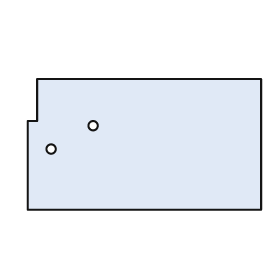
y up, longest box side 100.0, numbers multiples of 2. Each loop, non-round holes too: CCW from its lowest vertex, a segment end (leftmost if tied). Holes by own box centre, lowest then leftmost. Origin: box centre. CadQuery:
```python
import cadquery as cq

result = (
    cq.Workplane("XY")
    .moveTo(-50.0, -28.0)
    .lineTo(50.0, -28.0)
    .lineTo(50.0, 28.0)
    .lineTo(-46.0, 28.0)
    .lineTo(-46.0, 10.0)
    .lineTo(-50.0, 10.0)
    .close()
    .moveTo(-40.0, -2.0)
    .circle(2.0)
    .moveTo(-22.0, 8.0)
    .circle(2.0)
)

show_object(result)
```